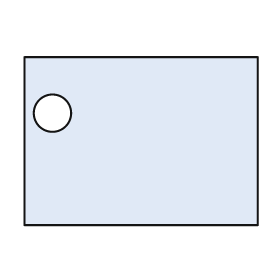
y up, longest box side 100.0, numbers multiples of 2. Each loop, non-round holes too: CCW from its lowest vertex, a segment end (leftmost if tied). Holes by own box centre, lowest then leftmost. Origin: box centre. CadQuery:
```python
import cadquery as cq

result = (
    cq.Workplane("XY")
    .moveTo(-50.0, -36.0)
    .lineTo(50.0, -36.0)
    .lineTo(50.0, 36.0)
    .lineTo(-50.0, 36.0)
    .close()
    .moveTo(-38.0, 12.0)
    .circle(8.0)
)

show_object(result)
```